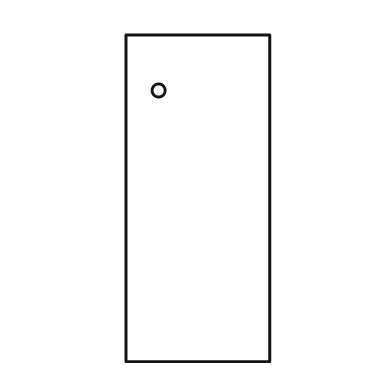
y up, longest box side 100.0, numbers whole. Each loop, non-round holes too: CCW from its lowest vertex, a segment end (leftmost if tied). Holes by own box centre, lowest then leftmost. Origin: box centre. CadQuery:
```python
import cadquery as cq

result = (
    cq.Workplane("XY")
    .moveTo(-22.0, -50.0)
    .lineTo(22.0, -50.0)
    .lineTo(22.0, 50.0)
    .lineTo(-22.0, 50.0)
    .close()
    .moveTo(-12.0, 33.0)
    .circle(2.0)
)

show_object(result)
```